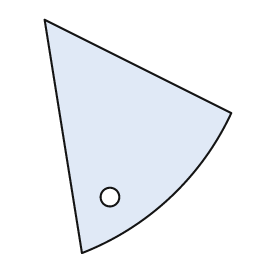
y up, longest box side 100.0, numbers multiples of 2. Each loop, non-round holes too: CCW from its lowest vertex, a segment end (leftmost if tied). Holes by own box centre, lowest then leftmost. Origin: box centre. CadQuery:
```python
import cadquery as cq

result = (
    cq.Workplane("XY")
    .moveTo(-24.0, -50.0)
    .threePointArc((14.0, -26.0), (40.0, 10.0))
    .lineTo(-40.0, 50.0)
    .close()
    .moveTo(-12.0, -26.0)
    .circle(4.0)
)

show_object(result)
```